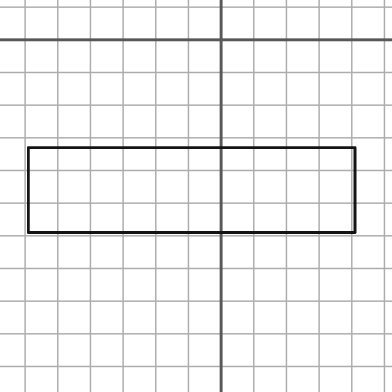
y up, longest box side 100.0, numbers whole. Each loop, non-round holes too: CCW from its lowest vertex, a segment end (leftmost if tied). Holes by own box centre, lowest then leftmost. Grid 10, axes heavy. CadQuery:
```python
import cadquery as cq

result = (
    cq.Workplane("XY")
    .moveTo(-59.0, -59.0)
    .lineTo(41.0, -59.0)
    .lineTo(41.0, -33.0)
    .lineTo(-59.0, -33.0)
    .close()
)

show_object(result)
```